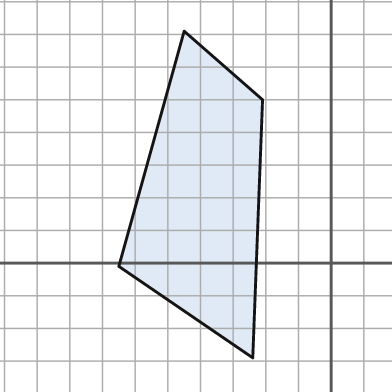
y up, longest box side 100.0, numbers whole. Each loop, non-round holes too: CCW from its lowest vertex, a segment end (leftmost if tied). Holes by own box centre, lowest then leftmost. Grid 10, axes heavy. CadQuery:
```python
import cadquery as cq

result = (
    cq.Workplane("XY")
    .moveTo(-24.0, -29.0)
    .lineTo(-21.0, 50.0)
    .lineTo(-45.0, 71.0)
    .lineTo(-65.0, -1.0)
    .close()
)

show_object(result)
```